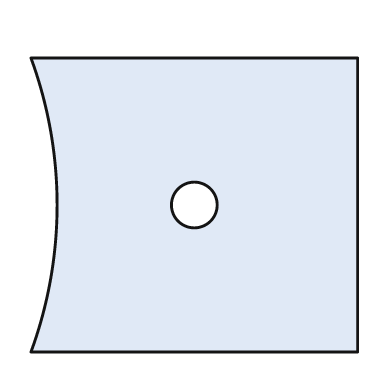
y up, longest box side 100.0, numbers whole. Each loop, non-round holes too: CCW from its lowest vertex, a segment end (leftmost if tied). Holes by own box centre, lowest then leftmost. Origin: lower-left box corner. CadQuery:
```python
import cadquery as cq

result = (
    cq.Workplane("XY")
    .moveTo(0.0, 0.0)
    .lineTo(100.0, 0.0)
    .lineTo(100.0, 90.0)
    .lineTo(0.0, 90.0)
    .threePointArc((8.0, 45.0), (0.0, 0.0))
    .close()
    .moveTo(50.0, 45.0)
    .circle(7.0)
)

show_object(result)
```